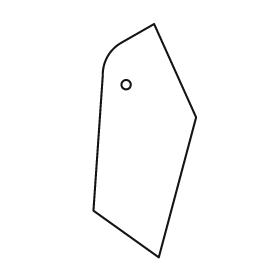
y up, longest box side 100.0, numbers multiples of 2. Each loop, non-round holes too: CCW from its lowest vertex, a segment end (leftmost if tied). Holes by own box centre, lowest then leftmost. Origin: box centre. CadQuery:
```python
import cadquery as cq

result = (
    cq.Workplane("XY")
    .moveTo(6.0, -50.0)
    .lineTo(22.0, 10.0)
    .lineTo(4.0, 50.0)
    .lineTo(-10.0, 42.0)
    .threePointArc((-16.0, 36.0), (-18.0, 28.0))
    .lineTo(-22.0, -30.0)
    .close()
    .moveTo(-8.0, 24.0)
    .circle(2.0)
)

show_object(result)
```